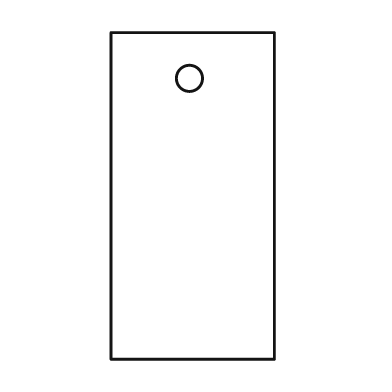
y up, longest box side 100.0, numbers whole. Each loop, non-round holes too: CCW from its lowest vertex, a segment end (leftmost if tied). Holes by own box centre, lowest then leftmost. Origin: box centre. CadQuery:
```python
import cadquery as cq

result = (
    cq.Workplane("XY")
    .moveTo(-25.0, -50.0)
    .lineTo(25.0, -50.0)
    .lineTo(25.0, 50.0)
    .lineTo(-25.0, 50.0)
    .close()
    .moveTo(-1.0, 36.0)
    .circle(4.0)
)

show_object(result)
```